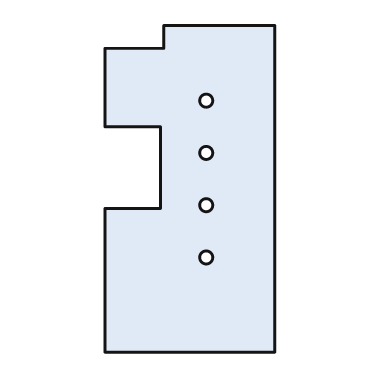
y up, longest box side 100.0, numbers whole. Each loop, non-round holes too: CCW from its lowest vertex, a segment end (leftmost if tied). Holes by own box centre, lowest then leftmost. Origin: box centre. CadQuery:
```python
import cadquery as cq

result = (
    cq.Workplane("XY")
    .moveTo(-26.0, -50.0)
    .lineTo(26.0, -50.0)
    .lineTo(26.0, 50.0)
    .lineTo(-8.0, 50.0)
    .lineTo(-8.0, 43.0)
    .lineTo(-26.0, 43.0)
    .lineTo(-26.0, 19.0)
    .lineTo(-9.0, 19.0)
    .lineTo(-9.0, -6.0)
    .lineTo(-26.0, -6.0)
    .close()
    .moveTo(5.0, -21.0)
    .circle(2.0)
    .moveTo(5.0, -5.0)
    .circle(2.0)
    .moveTo(5.0, 11.0)
    .circle(2.0)
    .moveTo(5.0, 27.0)
    .circle(2.0)
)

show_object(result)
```